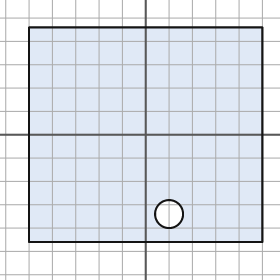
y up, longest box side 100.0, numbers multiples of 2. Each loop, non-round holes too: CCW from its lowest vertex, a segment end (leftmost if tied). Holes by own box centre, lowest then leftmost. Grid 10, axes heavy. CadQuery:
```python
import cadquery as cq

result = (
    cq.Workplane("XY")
    .moveTo(-50.0, -46.0)
    .lineTo(50.0, -46.0)
    .lineTo(50.0, 46.0)
    .lineTo(-50.0, 46.0)
    .close()
    .moveTo(10.0, -34.0)
    .circle(6.0)
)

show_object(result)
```